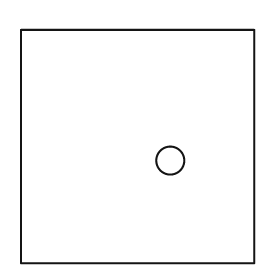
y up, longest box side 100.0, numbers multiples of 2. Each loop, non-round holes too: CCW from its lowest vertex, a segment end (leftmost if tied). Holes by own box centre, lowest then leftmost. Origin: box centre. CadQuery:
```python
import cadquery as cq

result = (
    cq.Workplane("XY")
    .moveTo(-50.0, -50.0)
    .lineTo(50.0, -50.0)
    .lineTo(50.0, 50.0)
    .lineTo(-50.0, 50.0)
    .close()
    .moveTo(14.0, -6.0)
    .circle(6.0)
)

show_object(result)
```